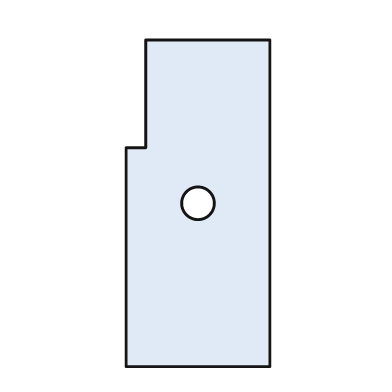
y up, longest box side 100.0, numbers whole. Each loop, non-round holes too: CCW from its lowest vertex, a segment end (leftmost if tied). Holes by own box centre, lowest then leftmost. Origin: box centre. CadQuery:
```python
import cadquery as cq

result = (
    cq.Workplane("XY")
    .moveTo(-22.0, -50.0)
    .lineTo(22.0, -50.0)
    .lineTo(22.0, 50.0)
    .lineTo(-16.0, 50.0)
    .lineTo(-16.0, 17.0)
    .lineTo(-22.0, 17.0)
    .close()
    .moveTo(0.0, 0.0)
    .circle(5.0)
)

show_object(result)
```